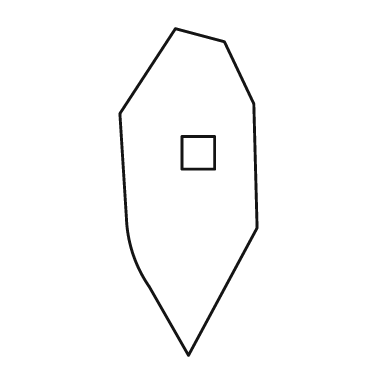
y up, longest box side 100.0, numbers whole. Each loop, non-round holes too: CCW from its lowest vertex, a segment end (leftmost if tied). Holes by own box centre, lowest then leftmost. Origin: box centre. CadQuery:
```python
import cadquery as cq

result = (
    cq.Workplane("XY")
    .moveTo(0.0, -50.0)
    .lineTo(21.0, -11.0)
    .lineTo(20.0, 27.0)
    .lineTo(11.0, 46.0)
    .lineTo(-4.0, 50.0)
    .lineTo(-21.0, 24.0)
    .lineTo(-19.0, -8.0)
    .threePointArc((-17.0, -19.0), (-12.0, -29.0))
    .close()
    .moveTo(-2.0, 7.0)
    .lineTo(8.0, 7.0)
    .lineTo(8.0, 17.0)
    .lineTo(-2.0, 17.0)
    .close()
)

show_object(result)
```